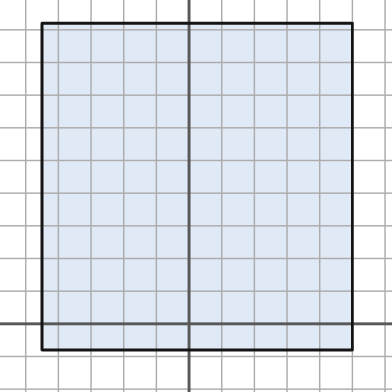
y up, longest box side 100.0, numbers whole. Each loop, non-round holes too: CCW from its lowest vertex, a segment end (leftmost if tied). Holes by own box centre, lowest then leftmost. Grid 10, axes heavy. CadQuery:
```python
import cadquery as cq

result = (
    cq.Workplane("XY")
    .moveTo(-45.0, -8.0)
    .lineTo(50.0, -8.0)
    .lineTo(50.0, 92.0)
    .lineTo(-45.0, 92.0)
    .close()
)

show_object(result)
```